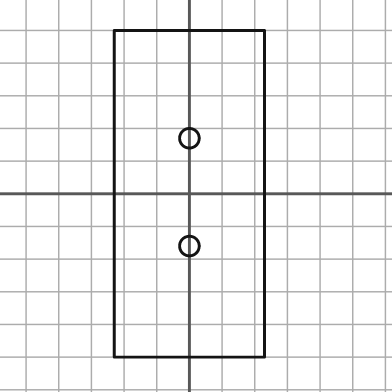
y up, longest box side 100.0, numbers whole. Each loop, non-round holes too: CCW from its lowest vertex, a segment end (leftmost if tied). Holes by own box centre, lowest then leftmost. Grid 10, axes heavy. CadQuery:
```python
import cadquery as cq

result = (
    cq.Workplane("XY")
    .moveTo(-23.0, -50.0)
    .lineTo(23.0, -50.0)
    .lineTo(23.0, 50.0)
    .lineTo(-23.0, 50.0)
    .close()
    .moveTo(0.0, -16.0)
    .circle(3.0)
    .moveTo(0.0, 17.0)
    .circle(3.0)
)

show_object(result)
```